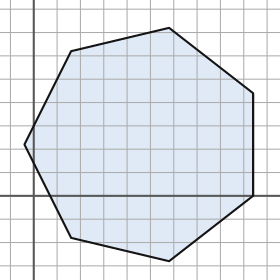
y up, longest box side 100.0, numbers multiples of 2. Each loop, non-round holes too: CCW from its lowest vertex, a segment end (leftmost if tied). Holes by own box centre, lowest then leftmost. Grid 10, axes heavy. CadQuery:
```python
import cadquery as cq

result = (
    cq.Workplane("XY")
    .moveTo(58.0, -28.0)
    .lineTo(94.0, 0.0)
    .lineTo(94.0, 44.0)
    .lineTo(58.0, 72.0)
    .lineTo(16.0, 62.0)
    .lineTo(-4.0, 22.0)
    .lineTo(16.0, -18.0)
    .close()
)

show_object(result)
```